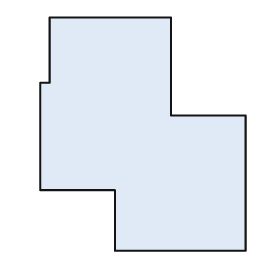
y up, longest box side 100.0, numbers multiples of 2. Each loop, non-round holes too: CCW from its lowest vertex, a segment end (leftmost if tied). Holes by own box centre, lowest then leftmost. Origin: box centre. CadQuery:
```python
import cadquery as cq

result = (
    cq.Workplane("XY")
    .moveTo(-12.0, -50.0)
    .lineTo(44.0, -50.0)
    .lineTo(44.0, 8.0)
    .lineTo(12.0, 8.0)
    .lineTo(12.0, 50.0)
    .lineTo(-40.0, 50.0)
    .lineTo(-40.0, 22.0)
    .lineTo(-44.0, 22.0)
    .lineTo(-44.0, -24.0)
    .lineTo(-12.0, -24.0)
    .close()
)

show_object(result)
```